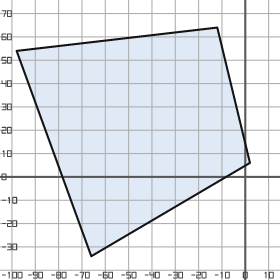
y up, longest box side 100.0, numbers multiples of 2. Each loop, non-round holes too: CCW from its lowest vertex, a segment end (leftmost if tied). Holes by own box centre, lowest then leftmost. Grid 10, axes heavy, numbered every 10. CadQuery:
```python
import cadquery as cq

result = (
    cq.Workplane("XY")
    .moveTo(-66.0, -34.0)
    .lineTo(2.0, 6.0)
    .lineTo(-12.0, 64.0)
    .lineTo(-98.0, 54.0)
    .close()
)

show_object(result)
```